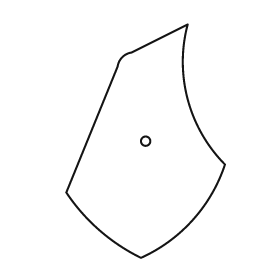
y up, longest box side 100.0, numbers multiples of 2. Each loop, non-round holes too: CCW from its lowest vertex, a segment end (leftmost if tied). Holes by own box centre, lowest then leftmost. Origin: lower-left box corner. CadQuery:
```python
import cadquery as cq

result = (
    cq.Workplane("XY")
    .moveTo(32.0, 0.0)
    .threePointArc((54.0, 16.0), (68.0, 40.0))
    .threePointArc((52.0, 68.0), (52.0, 100.0))
    .lineTo(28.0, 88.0)
    .threePointArc((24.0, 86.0), (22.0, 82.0))
    .lineTo(0.0, 28.0)
    .threePointArc((14.0, 12.0), (32.0, 0.0))
    .close()
    .moveTo(34.0, 50.0)
    .circle(2.0)
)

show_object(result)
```